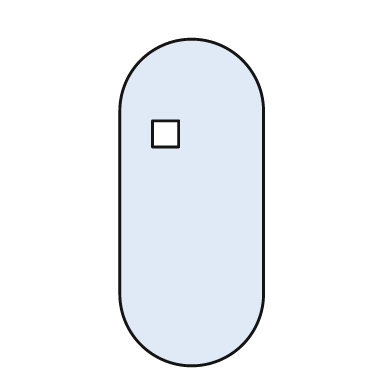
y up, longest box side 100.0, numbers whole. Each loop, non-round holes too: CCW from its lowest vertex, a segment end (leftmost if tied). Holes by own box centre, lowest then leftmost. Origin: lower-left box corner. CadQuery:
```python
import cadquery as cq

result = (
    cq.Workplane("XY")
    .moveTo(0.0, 22.0)
    .threePointArc((22.0, 0.0), (44.0, 22.0))
    .lineTo(44.0, 78.0)
    .threePointArc((22.0, 100.0), (0.0, 78.0))
    .close()
    .moveTo(10.0, 67.0)
    .lineTo(18.0, 67.0)
    .lineTo(18.0, 75.0)
    .lineTo(10.0, 75.0)
    .close()
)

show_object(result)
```